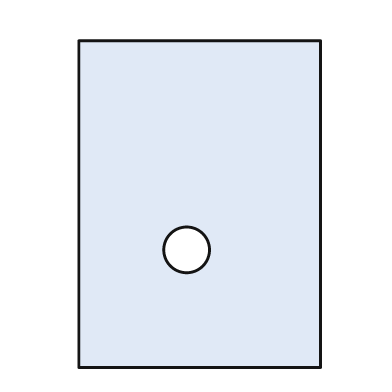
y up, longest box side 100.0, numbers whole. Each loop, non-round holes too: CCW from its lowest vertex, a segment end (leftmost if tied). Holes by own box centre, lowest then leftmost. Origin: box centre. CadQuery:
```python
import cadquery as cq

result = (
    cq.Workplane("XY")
    .moveTo(-37.0, -50.0)
    .lineTo(37.0, -50.0)
    .lineTo(37.0, 50.0)
    .lineTo(-37.0, 50.0)
    .close()
    .moveTo(-4.0, -14.0)
    .circle(7.0)
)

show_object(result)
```